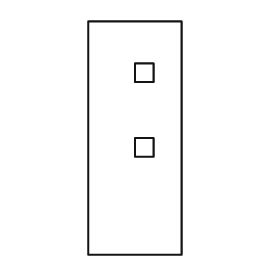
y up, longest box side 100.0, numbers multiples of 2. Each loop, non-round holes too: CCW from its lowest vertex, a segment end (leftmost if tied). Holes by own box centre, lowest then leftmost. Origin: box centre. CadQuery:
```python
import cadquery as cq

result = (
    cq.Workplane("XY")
    .moveTo(-20.0, -50.0)
    .lineTo(20.0, -50.0)
    .lineTo(20.0, 50.0)
    .lineTo(-20.0, 50.0)
    .close()
    .moveTo(0.0, -8.0)
    .lineTo(8.0, -8.0)
    .lineTo(8.0, 0.0)
    .lineTo(0.0, 0.0)
    .close()
    .moveTo(0.0, 24.0)
    .lineTo(8.0, 24.0)
    .lineTo(8.0, 32.0)
    .lineTo(0.0, 32.0)
    .close()
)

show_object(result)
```